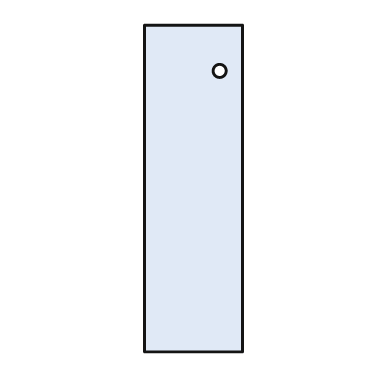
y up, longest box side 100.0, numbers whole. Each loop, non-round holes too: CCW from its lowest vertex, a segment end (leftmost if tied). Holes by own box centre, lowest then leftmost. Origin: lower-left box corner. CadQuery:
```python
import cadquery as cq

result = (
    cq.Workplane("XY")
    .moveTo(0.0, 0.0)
    .lineTo(30.0, 0.0)
    .lineTo(30.0, 100.0)
    .lineTo(0.0, 100.0)
    .close()
    .moveTo(23.0, 86.0)
    .circle(2.0)
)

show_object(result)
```